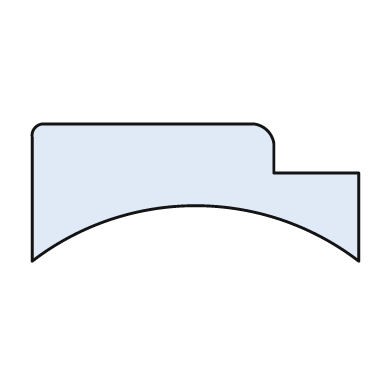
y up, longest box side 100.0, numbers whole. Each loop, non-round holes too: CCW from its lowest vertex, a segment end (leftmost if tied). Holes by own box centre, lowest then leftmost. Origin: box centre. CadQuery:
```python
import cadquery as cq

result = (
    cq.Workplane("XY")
    .moveTo(-50.0, -21.0)
    .threePointArc((0.0, -4.0), (50.0, -21.0))
    .lineTo(50.0, 6.0)
    .lineTo(24.0, 6.0)
    .lineTo(24.0, 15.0)
    .threePointArc((22.0, 19.0), (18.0, 21.0))
    .lineTo(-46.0, 21.0)
    .threePointArc((-49.0, 20.0), (-50.0, 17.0))
    .close()
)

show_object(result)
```